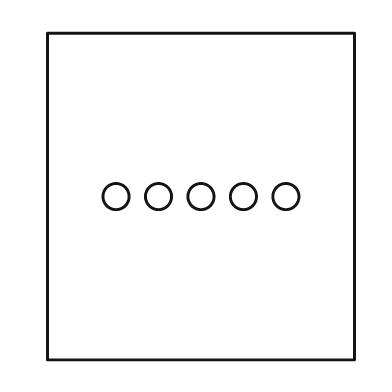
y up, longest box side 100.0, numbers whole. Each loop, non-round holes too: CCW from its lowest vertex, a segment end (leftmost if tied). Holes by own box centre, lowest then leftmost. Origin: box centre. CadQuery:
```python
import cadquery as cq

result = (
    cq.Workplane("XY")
    .moveTo(-47.0, -50.0)
    .lineTo(47.0, -50.0)
    .lineTo(47.0, 50.0)
    .lineTo(-47.0, 50.0)
    .close()
    .moveTo(-26.0, 0.0)
    .circle(4.0)
    .moveTo(-13.0, 0.0)
    .circle(4.0)
    .moveTo(0.0, 0.0)
    .circle(4.0)
    .moveTo(13.0, 0.0)
    .circle(4.0)
    .moveTo(26.0, 0.0)
    .circle(4.0)
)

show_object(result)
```